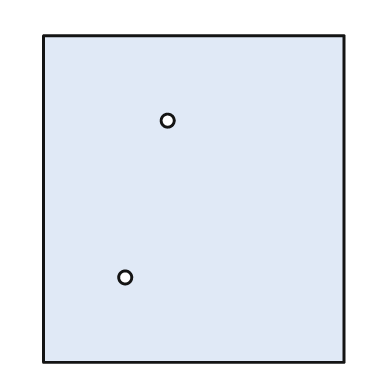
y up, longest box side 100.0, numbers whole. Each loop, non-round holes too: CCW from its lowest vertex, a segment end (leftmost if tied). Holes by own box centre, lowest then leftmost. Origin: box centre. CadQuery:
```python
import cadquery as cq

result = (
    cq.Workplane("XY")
    .moveTo(-46.0, -50.0)
    .lineTo(46.0, -50.0)
    .lineTo(46.0, 50.0)
    .lineTo(-46.0, 50.0)
    .close()
    .moveTo(-21.0, -24.0)
    .circle(2.0)
    .moveTo(-8.0, 24.0)
    .circle(2.0)
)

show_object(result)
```